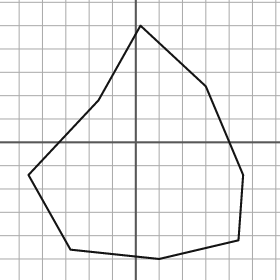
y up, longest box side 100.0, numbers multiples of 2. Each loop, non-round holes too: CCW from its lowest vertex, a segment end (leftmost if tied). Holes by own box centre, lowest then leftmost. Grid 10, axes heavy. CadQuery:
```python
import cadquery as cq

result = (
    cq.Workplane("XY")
    .moveTo(10.0, -50.0)
    .lineTo(44.0, -42.0)
    .lineTo(46.0, -14.0)
    .lineTo(30.0, 24.0)
    .lineTo(2.0, 50.0)
    .lineTo(-16.0, 18.0)
    .lineTo(-46.0, -14.0)
    .lineTo(-28.0, -46.0)
    .close()
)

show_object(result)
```